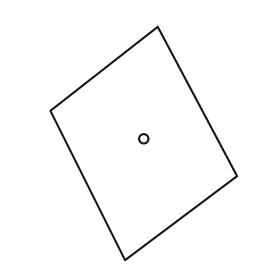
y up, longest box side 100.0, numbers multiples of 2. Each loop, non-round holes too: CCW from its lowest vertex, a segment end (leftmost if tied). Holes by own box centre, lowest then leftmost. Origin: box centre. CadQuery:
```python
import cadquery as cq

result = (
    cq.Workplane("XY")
    .moveTo(-8.0, -50.0)
    .lineTo(40.0, -14.0)
    .lineTo(6.0, 50.0)
    .lineTo(-40.0, 14.0)
    .close()
    .moveTo(0.0, 2.0)
    .circle(2.0)
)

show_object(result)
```